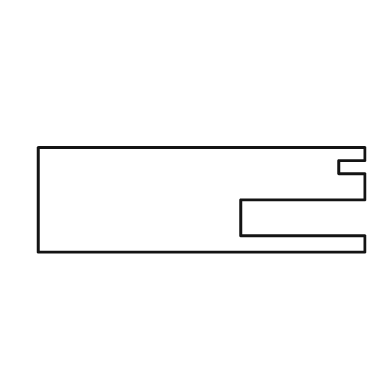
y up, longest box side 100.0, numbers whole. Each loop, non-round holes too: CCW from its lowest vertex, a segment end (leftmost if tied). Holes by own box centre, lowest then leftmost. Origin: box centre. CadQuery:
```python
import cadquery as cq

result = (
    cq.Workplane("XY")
    .moveTo(-50.0, -16.0)
    .lineTo(50.0, -16.0)
    .lineTo(50.0, -11.0)
    .lineTo(12.0, -11.0)
    .lineTo(12.0, 0.0)
    .lineTo(50.0, 0.0)
    .lineTo(50.0, 8.0)
    .lineTo(42.0, 8.0)
    .lineTo(42.0, 12.0)
    .lineTo(50.0, 12.0)
    .lineTo(50.0, 16.0)
    .lineTo(-50.0, 16.0)
    .close()
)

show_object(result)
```